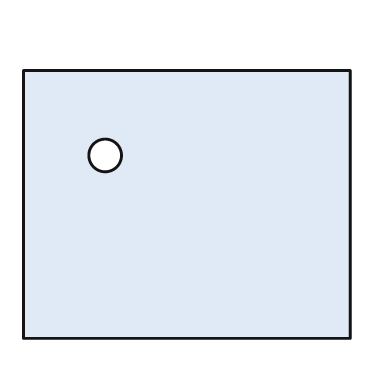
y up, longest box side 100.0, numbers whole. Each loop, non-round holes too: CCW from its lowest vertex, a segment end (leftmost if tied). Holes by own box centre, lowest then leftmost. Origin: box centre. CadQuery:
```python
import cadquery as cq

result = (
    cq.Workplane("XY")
    .moveTo(-50.0, -41.0)
    .lineTo(50.0, -41.0)
    .lineTo(50.0, 41.0)
    .lineTo(-50.0, 41.0)
    .close()
    .moveTo(-25.0, 15.0)
    .circle(5.0)
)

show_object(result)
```